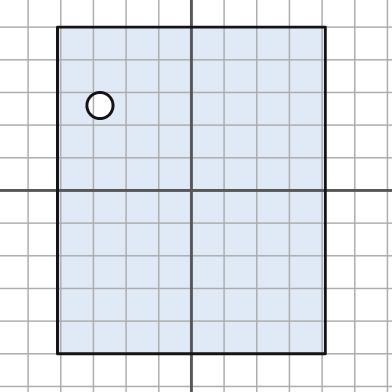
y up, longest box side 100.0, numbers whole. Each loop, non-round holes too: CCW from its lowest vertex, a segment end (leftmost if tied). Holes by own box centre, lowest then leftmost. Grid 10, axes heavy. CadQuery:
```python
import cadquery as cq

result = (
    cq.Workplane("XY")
    .moveTo(-41.0, -50.0)
    .lineTo(41.0, -50.0)
    .lineTo(41.0, 50.0)
    .lineTo(-41.0, 50.0)
    .close()
    .moveTo(-28.0, 26.0)
    .circle(4.0)
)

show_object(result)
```